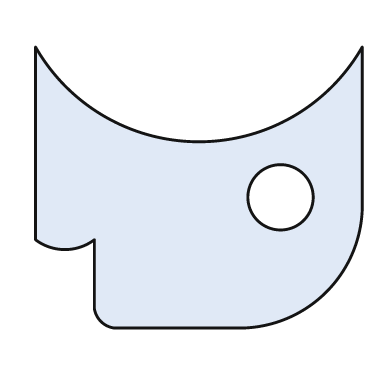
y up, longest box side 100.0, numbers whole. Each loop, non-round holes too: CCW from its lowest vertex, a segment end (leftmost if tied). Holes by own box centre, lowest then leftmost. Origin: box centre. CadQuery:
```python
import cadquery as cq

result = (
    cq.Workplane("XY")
    .moveTo(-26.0, -43.0)
    .lineTo(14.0, -43.0)
    .threePointArc((39.0, -32.0), (50.0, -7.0))
    .lineTo(50.0, 43.0)
    .threePointArc((0.0, 14.0), (-50.0, 43.0))
    .lineTo(-50.0, -16.0)
    .threePointArc((-41.0, -19.0), (-32.0, -16.0))
    .lineTo(-32.0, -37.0)
    .threePointArc((-30.0, -41.0), (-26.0, -43.0))
    .close()
    .moveTo(25.0, -3.0)
    .circle(10.0)
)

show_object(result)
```